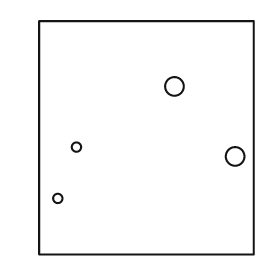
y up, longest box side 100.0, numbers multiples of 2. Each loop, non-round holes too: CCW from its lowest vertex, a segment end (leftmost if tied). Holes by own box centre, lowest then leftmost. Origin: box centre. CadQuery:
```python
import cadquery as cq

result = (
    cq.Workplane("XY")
    .moveTo(-46.0, -50.0)
    .lineTo(46.0, -50.0)
    .lineTo(46.0, 50.0)
    .lineTo(-46.0, 50.0)
    .close()
    .moveTo(-38.0, -26.0)
    .circle(2.0)
    .moveTo(38.0, -8.0)
    .circle(4.0)
    .moveTo(-30.0, -4.0)
    .circle(2.0)
    .moveTo(12.0, 22.0)
    .circle(4.0)
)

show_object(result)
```